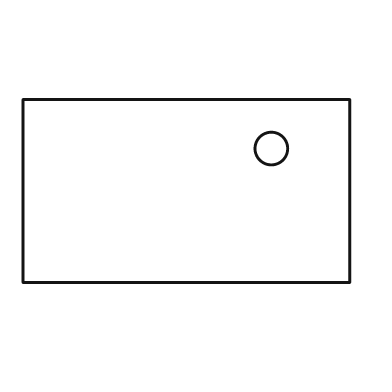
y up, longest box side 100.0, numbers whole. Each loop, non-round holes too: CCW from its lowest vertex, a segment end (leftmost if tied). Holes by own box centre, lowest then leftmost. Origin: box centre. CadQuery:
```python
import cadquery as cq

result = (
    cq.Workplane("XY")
    .moveTo(-50.0, -28.0)
    .lineTo(50.0, -28.0)
    .lineTo(50.0, 28.0)
    .lineTo(-50.0, 28.0)
    .close()
    .moveTo(26.0, 13.0)
    .circle(5.0)
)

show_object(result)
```